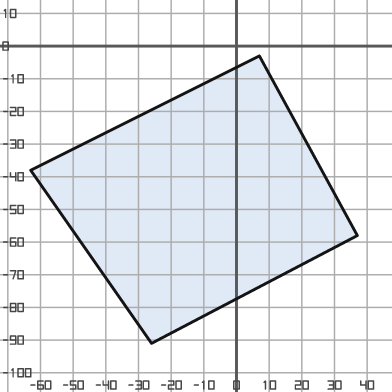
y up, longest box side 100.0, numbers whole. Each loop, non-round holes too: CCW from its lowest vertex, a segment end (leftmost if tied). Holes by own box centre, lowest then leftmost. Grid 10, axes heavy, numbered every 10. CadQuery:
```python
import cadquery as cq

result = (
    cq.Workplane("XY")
    .moveTo(-26.0, -91.0)
    .lineTo(37.0, -58.0)
    .lineTo(7.0, -3.0)
    .lineTo(-63.0, -38.0)
    .close()
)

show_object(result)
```